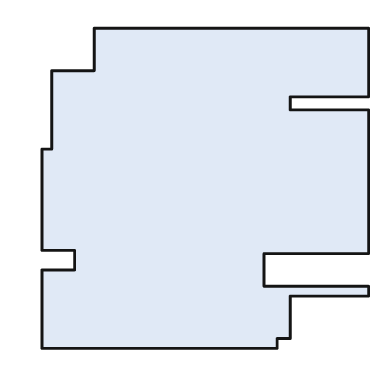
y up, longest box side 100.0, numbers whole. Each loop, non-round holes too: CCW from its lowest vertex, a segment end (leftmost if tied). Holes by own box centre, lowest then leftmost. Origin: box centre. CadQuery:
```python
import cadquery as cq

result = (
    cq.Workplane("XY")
    .moveTo(-50.0, -49.0)
    .lineTo(22.0, -49.0)
    .lineTo(22.0, -46.0)
    .lineTo(26.0, -46.0)
    .lineTo(26.0, -33.0)
    .lineTo(50.0, -33.0)
    .lineTo(50.0, -30.0)
    .lineTo(18.0, -30.0)
    .lineTo(18.0, -20.0)
    .lineTo(50.0, -20.0)
    .lineTo(50.0, 24.0)
    .lineTo(26.0, 24.0)
    .lineTo(26.0, 28.0)
    .lineTo(50.0, 28.0)
    .lineTo(50.0, 49.0)
    .lineTo(-34.0, 49.0)
    .lineTo(-34.0, 36.0)
    .lineTo(-47.0, 36.0)
    .lineTo(-47.0, 12.0)
    .lineTo(-50.0, 12.0)
    .lineTo(-50.0, -19.0)
    .lineTo(-40.0, -19.0)
    .lineTo(-40.0, -25.0)
    .lineTo(-50.0, -25.0)
    .close()
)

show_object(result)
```